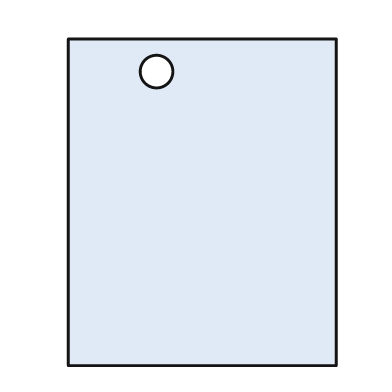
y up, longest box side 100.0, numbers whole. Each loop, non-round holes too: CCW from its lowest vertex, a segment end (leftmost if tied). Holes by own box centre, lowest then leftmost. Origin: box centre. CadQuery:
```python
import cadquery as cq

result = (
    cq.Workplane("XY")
    .moveTo(-41.0, -50.0)
    .lineTo(41.0, -50.0)
    .lineTo(41.0, 50.0)
    .lineTo(-41.0, 50.0)
    .close()
    .moveTo(-14.0, 40.0)
    .circle(5.0)
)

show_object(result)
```